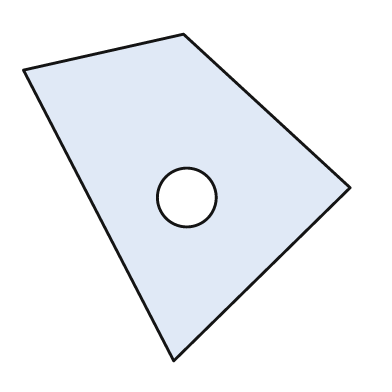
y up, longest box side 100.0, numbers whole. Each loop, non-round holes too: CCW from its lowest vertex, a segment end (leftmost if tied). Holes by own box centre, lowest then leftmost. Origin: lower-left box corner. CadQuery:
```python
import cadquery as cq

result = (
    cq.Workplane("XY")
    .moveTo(46.0, 0.0)
    .lineTo(100.0, 53.0)
    .lineTo(49.0, 100.0)
    .lineTo(0.0, 89.0)
    .close()
    .moveTo(50.0, 50.0)
    .circle(9.0)
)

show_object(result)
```